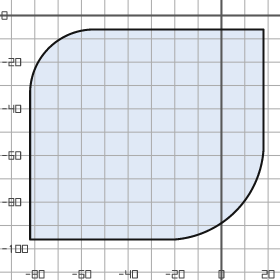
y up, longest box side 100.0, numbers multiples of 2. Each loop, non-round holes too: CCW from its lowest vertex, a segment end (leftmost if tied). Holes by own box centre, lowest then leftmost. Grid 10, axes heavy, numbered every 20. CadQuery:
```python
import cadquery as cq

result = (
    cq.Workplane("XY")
    .moveTo(-82.0, -96.0)
    .lineTo(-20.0, -96.0)
    .threePointArc((6.0, -84.0), (18.0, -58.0))
    .lineTo(18.0, -6.0)
    .lineTo(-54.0, -6.0)
    .threePointArc((-74.0, -14.0), (-82.0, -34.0))
    .close()
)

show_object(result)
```